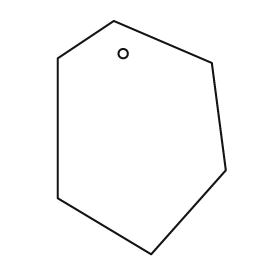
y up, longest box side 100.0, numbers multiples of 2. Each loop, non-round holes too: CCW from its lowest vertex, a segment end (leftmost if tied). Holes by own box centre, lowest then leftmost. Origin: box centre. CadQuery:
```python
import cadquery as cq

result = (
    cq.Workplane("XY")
    .moveTo(4.0, -50.0)
    .lineTo(36.0, -14.0)
    .lineTo(30.0, 32.0)
    .lineTo(-12.0, 50.0)
    .lineTo(-36.0, 34.0)
    .lineTo(-36.0, -26.0)
    .close()
    .moveTo(-8.0, 36.0)
    .circle(2.0)
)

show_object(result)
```